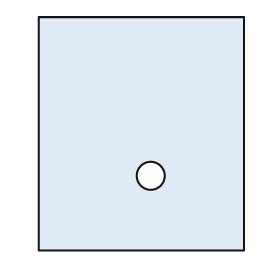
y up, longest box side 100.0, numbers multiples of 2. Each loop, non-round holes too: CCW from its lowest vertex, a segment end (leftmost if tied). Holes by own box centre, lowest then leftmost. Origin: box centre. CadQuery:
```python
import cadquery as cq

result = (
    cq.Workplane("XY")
    .moveTo(-44.0, -50.0)
    .lineTo(44.0, -50.0)
    .lineTo(44.0, 50.0)
    .lineTo(-44.0, 50.0)
    .close()
    .moveTo(4.0, -18.0)
    .circle(6.0)
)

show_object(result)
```